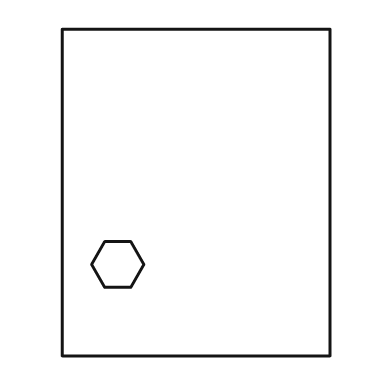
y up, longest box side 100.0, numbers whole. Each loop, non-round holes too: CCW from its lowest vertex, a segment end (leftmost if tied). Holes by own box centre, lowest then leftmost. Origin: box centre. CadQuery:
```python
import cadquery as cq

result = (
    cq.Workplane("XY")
    .moveTo(-41.0, -50.0)
    .lineTo(41.0, -50.0)
    .lineTo(41.0, 50.0)
    .lineTo(-41.0, 50.0)
    .close()
    .moveTo(-28.0, -29.0)
    .lineTo(-20.0, -29.0)
    .lineTo(-16.0, -22.0)
    .lineTo(-20.0, -15.0)
    .lineTo(-28.0, -15.0)
    .lineTo(-32.0, -22.0)
    .close()
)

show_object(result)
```